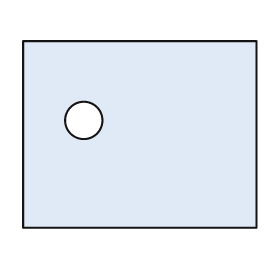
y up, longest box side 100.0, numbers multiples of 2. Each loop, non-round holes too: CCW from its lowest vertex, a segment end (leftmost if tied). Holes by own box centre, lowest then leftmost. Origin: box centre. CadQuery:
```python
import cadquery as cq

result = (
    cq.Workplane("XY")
    .moveTo(-50.0, -40.0)
    .lineTo(50.0, -40.0)
    .lineTo(50.0, 40.0)
    .lineTo(-50.0, 40.0)
    .close()
    .moveTo(-24.0, 6.0)
    .circle(8.0)
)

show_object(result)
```